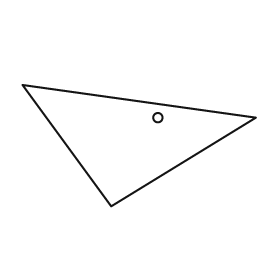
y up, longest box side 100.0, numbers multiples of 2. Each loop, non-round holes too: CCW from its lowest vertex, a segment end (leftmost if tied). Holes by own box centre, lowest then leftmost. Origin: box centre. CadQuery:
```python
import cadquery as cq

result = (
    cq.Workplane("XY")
    .moveTo(-12.0, -26.0)
    .lineTo(50.0, 12.0)
    .lineTo(-50.0, 26.0)
    .close()
    .moveTo(8.0, 12.0)
    .circle(2.0)
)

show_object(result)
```